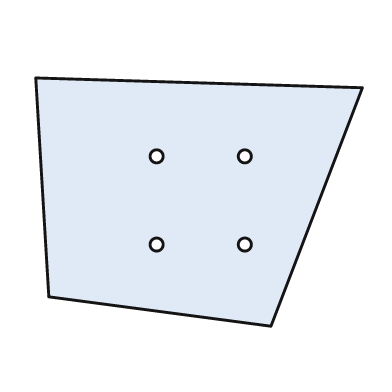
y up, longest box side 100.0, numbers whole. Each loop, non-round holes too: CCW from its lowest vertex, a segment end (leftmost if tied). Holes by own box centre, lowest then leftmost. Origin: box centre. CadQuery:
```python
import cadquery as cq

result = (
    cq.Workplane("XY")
    .moveTo(22.0, -38.0)
    .lineTo(50.0, 35.0)
    .lineTo(-50.0, 38.0)
    .lineTo(-46.0, -29.0)
    .close()
    .moveTo(-13.0, -13.0)
    .circle(2.0)
    .moveTo(14.0, -13.0)
    .circle(2.0)
    .moveTo(-13.0, 14.0)
    .circle(2.0)
    .moveTo(14.0, 14.0)
    .circle(2.0)
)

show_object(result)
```